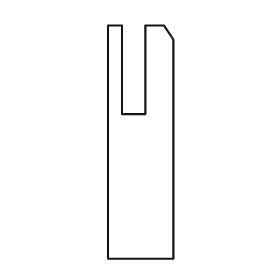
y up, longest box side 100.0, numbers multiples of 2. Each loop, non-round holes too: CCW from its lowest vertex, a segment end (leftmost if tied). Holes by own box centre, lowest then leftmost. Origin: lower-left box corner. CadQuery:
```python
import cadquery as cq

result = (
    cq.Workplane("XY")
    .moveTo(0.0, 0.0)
    .lineTo(28.0, 0.0)
    .lineTo(28.0, 94.0)
    .lineTo(24.0, 100.0)
    .lineTo(16.0, 100.0)
    .lineTo(16.0, 62.0)
    .lineTo(6.0, 62.0)
    .lineTo(6.0, 100.0)
    .lineTo(0.0, 100.0)
    .close()
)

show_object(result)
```